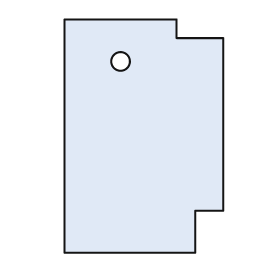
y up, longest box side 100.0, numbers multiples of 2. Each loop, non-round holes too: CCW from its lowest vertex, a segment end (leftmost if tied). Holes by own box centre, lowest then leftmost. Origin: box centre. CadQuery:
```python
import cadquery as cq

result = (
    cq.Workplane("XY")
    .moveTo(-34.0, -50.0)
    .lineTo(22.0, -50.0)
    .lineTo(22.0, -32.0)
    .lineTo(34.0, -32.0)
    .lineTo(34.0, 42.0)
    .lineTo(14.0, 42.0)
    .lineTo(14.0, 50.0)
    .lineTo(-34.0, 50.0)
    .close()
    .moveTo(-10.0, 32.0)
    .circle(4.0)
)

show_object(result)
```